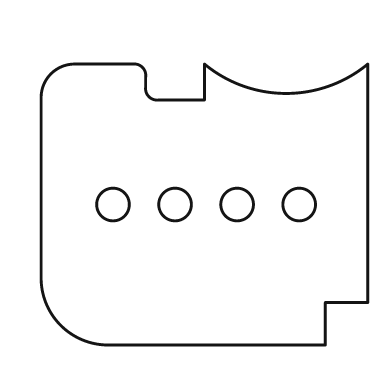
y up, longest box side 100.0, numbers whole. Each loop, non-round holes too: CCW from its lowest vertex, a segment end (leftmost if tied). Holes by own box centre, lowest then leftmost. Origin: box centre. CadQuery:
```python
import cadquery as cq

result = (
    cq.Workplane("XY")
    .moveTo(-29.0, -43.0)
    .lineTo(37.0, -43.0)
    .lineTo(37.0, -30.0)
    .lineTo(50.0, -30.0)
    .lineTo(50.0, 43.0)
    .threePointArc((25.0, 34.0), (0.0, 43.0))
    .lineTo(0.0, 32.0)
    .lineTo(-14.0, 32.0)
    .threePointArc((-17.0, 33.0), (-18.0, 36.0))
    .lineTo(-18.0, 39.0)
    .threePointArc((-19.0, 42.0), (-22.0, 43.0))
    .lineTo(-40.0, 43.0)
    .threePointArc((-47.0, 40.0), (-50.0, 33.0))
    .lineTo(-50.0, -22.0)
    .threePointArc((-44.0, -37.0), (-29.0, -43.0))
    .close()
    .moveTo(-28.0, 0.0)
    .circle(5.0)
    .moveTo(-9.0, 0.0)
    .circle(5.0)
    .moveTo(10.0, 0.0)
    .circle(5.0)
    .moveTo(29.0, 0.0)
    .circle(5.0)
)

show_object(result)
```